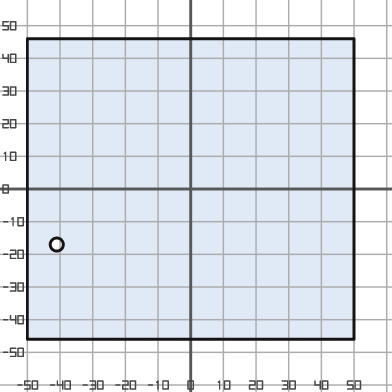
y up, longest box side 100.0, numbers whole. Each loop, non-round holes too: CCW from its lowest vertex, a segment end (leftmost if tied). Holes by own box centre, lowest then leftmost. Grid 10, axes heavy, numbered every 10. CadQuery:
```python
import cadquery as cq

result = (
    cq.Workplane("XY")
    .moveTo(-50.0, -46.0)
    .lineTo(50.0, -46.0)
    .lineTo(50.0, 46.0)
    .lineTo(-50.0, 46.0)
    .close()
    .moveTo(-41.0, -17.0)
    .circle(2.0)
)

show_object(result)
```